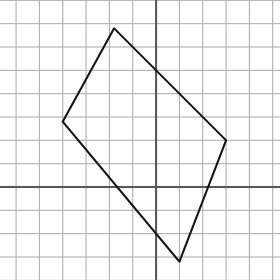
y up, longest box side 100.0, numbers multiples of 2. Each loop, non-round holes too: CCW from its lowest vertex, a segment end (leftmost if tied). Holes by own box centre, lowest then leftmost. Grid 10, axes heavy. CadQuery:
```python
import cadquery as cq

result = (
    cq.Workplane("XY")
    .moveTo(10.0, -32.0)
    .lineTo(30.0, 20.0)
    .lineTo(-18.0, 68.0)
    .lineTo(-40.0, 28.0)
    .close()
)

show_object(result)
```